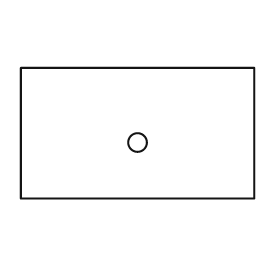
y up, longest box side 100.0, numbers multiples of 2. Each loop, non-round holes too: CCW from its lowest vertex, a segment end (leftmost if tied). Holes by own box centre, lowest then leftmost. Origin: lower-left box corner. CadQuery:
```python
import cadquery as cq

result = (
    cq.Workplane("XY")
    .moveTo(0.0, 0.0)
    .lineTo(100.0, 0.0)
    .lineTo(100.0, 56.0)
    .lineTo(0.0, 56.0)
    .close()
    .moveTo(50.0, 24.0)
    .circle(4.0)
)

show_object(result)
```